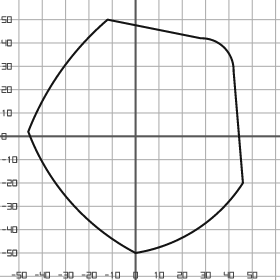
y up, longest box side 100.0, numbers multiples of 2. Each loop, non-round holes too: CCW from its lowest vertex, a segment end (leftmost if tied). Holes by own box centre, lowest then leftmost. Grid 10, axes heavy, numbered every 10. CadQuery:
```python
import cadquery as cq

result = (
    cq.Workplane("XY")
    .moveTo(0.0, -50.0)
    .threePointArc((26.0, -40.0), (46.0, -20.0))
    .lineTo(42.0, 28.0)
    .threePointArc((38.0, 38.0), (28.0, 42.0))
    .lineTo(-12.0, 50.0)
    .threePointArc((-32.0, 28.0), (-46.0, 2.0))
    .threePointArc((-28.0, -28.0), (0.0, -50.0))
    .close()
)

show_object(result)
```